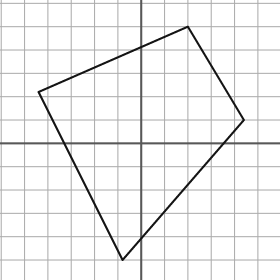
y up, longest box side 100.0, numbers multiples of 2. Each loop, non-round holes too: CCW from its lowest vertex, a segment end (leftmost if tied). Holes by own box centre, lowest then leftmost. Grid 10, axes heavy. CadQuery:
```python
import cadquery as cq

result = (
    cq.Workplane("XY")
    .moveTo(-8.0, -50.0)
    .lineTo(44.0, 10.0)
    .lineTo(20.0, 50.0)
    .lineTo(-44.0, 22.0)
    .close()
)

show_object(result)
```